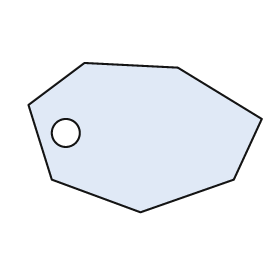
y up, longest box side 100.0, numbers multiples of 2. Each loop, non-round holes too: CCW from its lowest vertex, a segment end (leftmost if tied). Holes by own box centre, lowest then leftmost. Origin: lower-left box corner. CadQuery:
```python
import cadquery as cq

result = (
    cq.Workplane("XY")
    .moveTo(48.0, 0.0)
    .lineTo(88.0, 14.0)
    .lineTo(100.0, 40.0)
    .lineTo(64.0, 62.0)
    .lineTo(24.0, 64.0)
    .lineTo(0.0, 46.0)
    .lineTo(10.0, 14.0)
    .close()
    .moveTo(16.0, 34.0)
    .circle(6.0)
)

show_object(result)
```